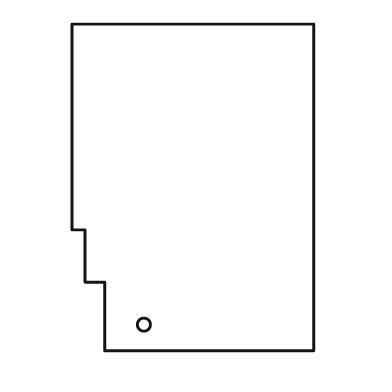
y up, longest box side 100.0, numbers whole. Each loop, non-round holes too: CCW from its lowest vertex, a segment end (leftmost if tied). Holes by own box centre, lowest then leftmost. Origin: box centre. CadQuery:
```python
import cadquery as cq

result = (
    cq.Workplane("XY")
    .moveTo(-27.0, -50.0)
    .lineTo(37.0, -50.0)
    .lineTo(37.0, 50.0)
    .lineTo(-37.0, 50.0)
    .lineTo(-37.0, -13.0)
    .lineTo(-33.0, -13.0)
    .lineTo(-33.0, -29.0)
    .lineTo(-27.0, -29.0)
    .close()
    .moveTo(-15.0, -42.0)
    .circle(2.0)
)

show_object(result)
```